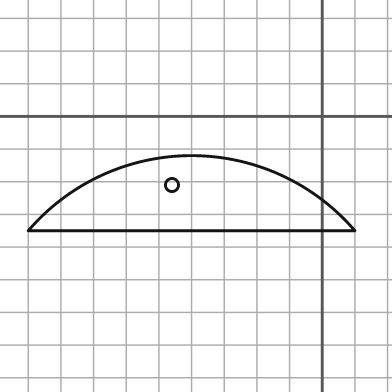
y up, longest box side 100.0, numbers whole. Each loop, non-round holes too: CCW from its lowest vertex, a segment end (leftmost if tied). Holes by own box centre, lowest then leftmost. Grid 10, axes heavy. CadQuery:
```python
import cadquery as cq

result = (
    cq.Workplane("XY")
    .moveTo(-90.0, -35.0)
    .lineTo(10.0, -35.0)
    .threePointArc((-40.0, -12.0), (-90.0, -35.0))
    .close()
    .moveTo(-46.0, -21.0)
    .circle(2.0)
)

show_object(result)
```